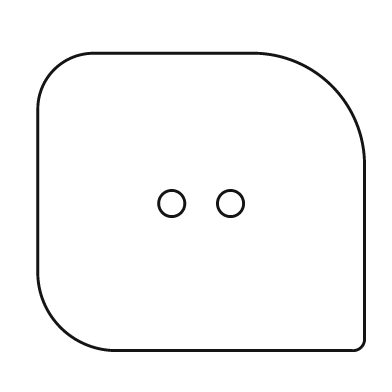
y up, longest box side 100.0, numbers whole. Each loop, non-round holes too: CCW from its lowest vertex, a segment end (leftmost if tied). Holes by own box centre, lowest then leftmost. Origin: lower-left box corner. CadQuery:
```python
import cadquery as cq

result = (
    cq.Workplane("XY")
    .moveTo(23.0, 0.0)
    .lineTo(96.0, 0.0)
    .threePointArc((99.0, 1.0), (100.0, 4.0))
    .lineTo(100.0, 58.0)
    .threePointArc((90.0, 81.0), (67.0, 91.0))
    .lineTo(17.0, 91.0)
    .threePointArc((5.0, 86.0), (0.0, 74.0))
    .lineTo(0.0, 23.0)
    .threePointArc((7.0, 7.0), (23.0, 0.0))
    .close()
    .moveTo(41.0, 45.0)
    .circle(4.0)
    .moveTo(59.0, 45.0)
    .circle(4.0)
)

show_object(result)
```